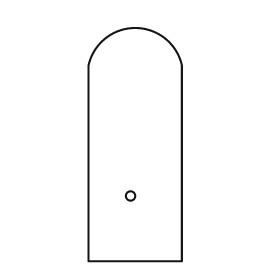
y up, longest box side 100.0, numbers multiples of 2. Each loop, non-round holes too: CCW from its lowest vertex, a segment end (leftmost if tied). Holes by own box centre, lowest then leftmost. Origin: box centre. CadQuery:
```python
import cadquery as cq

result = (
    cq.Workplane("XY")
    .moveTo(-20.0, -50.0)
    .lineTo(20.0, -50.0)
    .lineTo(20.0, 34.0)
    .threePointArc((0.0, 50.0), (-20.0, 34.0))
    .close()
    .moveTo(-2.0, -22.0)
    .circle(2.0)
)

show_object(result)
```